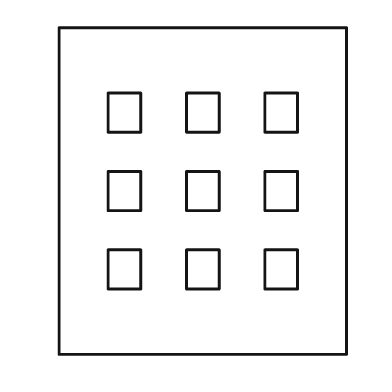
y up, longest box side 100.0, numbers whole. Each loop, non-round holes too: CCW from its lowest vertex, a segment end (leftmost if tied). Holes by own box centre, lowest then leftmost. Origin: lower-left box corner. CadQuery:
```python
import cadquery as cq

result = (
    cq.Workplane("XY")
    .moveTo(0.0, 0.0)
    .lineTo(88.0, 0.0)
    .lineTo(88.0, 100.0)
    .lineTo(0.0, 100.0)
    .close()
    .moveTo(15.0, 20.0)
    .lineTo(25.0, 20.0)
    .lineTo(25.0, 32.0)
    .lineTo(15.0, 32.0)
    .close()
    .moveTo(39.0, 20.0)
    .lineTo(49.0, 20.0)
    .lineTo(49.0, 32.0)
    .lineTo(39.0, 32.0)
    .close()
    .moveTo(63.0, 20.0)
    .lineTo(73.0, 20.0)
    .lineTo(73.0, 32.0)
    .lineTo(63.0, 32.0)
    .close()
    .moveTo(15.0, 44.0)
    .lineTo(25.0, 44.0)
    .lineTo(25.0, 56.0)
    .lineTo(15.0, 56.0)
    .close()
    .moveTo(39.0, 44.0)
    .lineTo(49.0, 44.0)
    .lineTo(49.0, 56.0)
    .lineTo(39.0, 56.0)
    .close()
    .moveTo(63.0, 44.0)
    .lineTo(73.0, 44.0)
    .lineTo(73.0, 56.0)
    .lineTo(63.0, 56.0)
    .close()
    .moveTo(15.0, 68.0)
    .lineTo(25.0, 68.0)
    .lineTo(25.0, 80.0)
    .lineTo(15.0, 80.0)
    .close()
    .moveTo(39.0, 68.0)
    .lineTo(49.0, 68.0)
    .lineTo(49.0, 80.0)
    .lineTo(39.0, 80.0)
    .close()
    .moveTo(63.0, 68.0)
    .lineTo(73.0, 68.0)
    .lineTo(73.0, 80.0)
    .lineTo(63.0, 80.0)
    .close()
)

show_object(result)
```